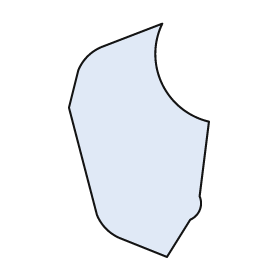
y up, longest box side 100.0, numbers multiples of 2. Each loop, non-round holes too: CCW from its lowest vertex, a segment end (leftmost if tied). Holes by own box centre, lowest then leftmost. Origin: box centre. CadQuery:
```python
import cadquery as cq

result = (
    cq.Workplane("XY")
    .moveTo(12.0, -50.0)
    .lineTo(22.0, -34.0)
    .threePointArc((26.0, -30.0), (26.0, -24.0))
    .lineTo(30.0, 8.0)
    .threePointArc((10.0, 24.0), (10.0, 50.0))
    .lineTo(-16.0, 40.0)
    .threePointArc((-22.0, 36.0), (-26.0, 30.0))
    .lineTo(-30.0, 14.0)
    .lineTo(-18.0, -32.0)
    .threePointArc((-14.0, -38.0), (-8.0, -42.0))
    .close()
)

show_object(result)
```